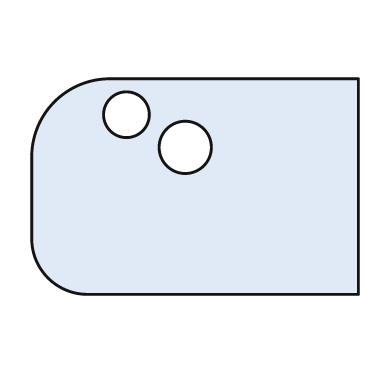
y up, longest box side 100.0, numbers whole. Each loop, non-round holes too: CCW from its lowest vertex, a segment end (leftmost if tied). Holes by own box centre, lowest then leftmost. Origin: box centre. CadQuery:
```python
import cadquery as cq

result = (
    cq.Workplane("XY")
    .moveTo(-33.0, -33.0)
    .lineTo(50.0, -33.0)
    .lineTo(50.0, 33.0)
    .lineTo(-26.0, 33.0)
    .threePointArc((-43.0, 26.0), (-50.0, 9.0))
    .lineTo(-50.0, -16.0)
    .threePointArc((-45.0, -28.0), (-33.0, -33.0))
    .close()
    .moveTo(-3.0, 12.0)
    .circle(8.0)
    .moveTo(-21.0, 22.0)
    .circle(7.0)
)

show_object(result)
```